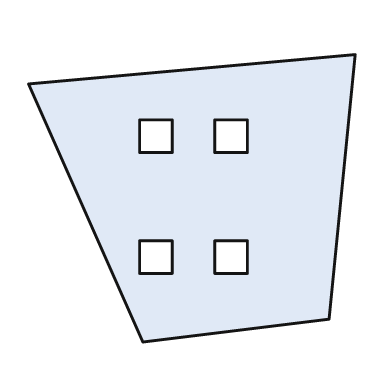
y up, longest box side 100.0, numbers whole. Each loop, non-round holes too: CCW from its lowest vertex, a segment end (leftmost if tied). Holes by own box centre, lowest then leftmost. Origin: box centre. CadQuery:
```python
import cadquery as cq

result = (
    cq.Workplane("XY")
    .moveTo(-15.0, -44.0)
    .lineTo(42.0, -37.0)
    .lineTo(50.0, 44.0)
    .lineTo(-50.0, 35.0)
    .close()
    .moveTo(-16.0, -23.0)
    .lineTo(-6.0, -23.0)
    .lineTo(-6.0, -13.0)
    .lineTo(-16.0, -13.0)
    .close()
    .moveTo(7.0, -23.0)
    .lineTo(17.0, -23.0)
    .lineTo(17.0, -13.0)
    .lineTo(7.0, -13.0)
    .close()
    .moveTo(-16.0, 14.0)
    .lineTo(-6.0, 14.0)
    .lineTo(-6.0, 24.0)
    .lineTo(-16.0, 24.0)
    .close()
    .moveTo(7.0, 14.0)
    .lineTo(17.0, 14.0)
    .lineTo(17.0, 24.0)
    .lineTo(7.0, 24.0)
    .close()
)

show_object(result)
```